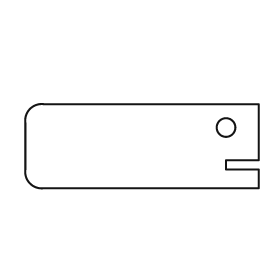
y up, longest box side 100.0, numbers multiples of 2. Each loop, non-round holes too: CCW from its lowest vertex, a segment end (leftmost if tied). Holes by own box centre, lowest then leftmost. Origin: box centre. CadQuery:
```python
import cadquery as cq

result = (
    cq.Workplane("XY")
    .moveTo(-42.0, -18.0)
    .lineTo(50.0, -18.0)
    .lineTo(50.0, -10.0)
    .lineTo(36.0, -10.0)
    .lineTo(36.0, -6.0)
    .lineTo(50.0, -6.0)
    .lineTo(50.0, 18.0)
    .lineTo(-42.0, 18.0)
    .threePointArc((-48.0, 16.0), (-50.0, 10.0))
    .lineTo(-50.0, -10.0)
    .threePointArc((-48.0, -16.0), (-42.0, -18.0))
    .close()
    .moveTo(36.0, 8.0)
    .circle(4.0)
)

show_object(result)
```